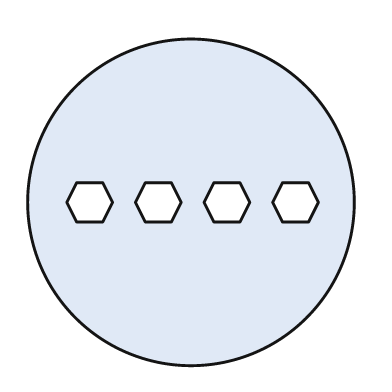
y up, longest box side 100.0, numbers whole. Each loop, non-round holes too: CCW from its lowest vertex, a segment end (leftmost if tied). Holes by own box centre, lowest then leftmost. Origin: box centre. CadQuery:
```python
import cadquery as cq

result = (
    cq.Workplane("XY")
    .moveTo(0.0, 0.0)
    .circle(50.0)
    .moveTo(-35.0, -6.0)
    .lineTo(-27.0, -6.0)
    .lineTo(-24.0, 0.0)
    .lineTo(-27.0, 6.0)
    .lineTo(-35.0, 6.0)
    .lineTo(-38.0, 0.0)
    .close()
    .moveTo(-14.0, -6.0)
    .lineTo(-6.0, -6.0)
    .lineTo(-3.0, 0.0)
    .lineTo(-6.0, 6.0)
    .lineTo(-14.0, 6.0)
    .lineTo(-17.0, 0.0)
    .close()
    .moveTo(7.0, -6.0)
    .lineTo(15.0, -6.0)
    .lineTo(18.0, 0.0)
    .lineTo(15.0, 6.0)
    .lineTo(7.0, 6.0)
    .lineTo(4.0, 0.0)
    .close()
    .moveTo(28.0, -6.0)
    .lineTo(36.0, -6.0)
    .lineTo(39.0, 0.0)
    .lineTo(36.0, 6.0)
    .lineTo(28.0, 6.0)
    .lineTo(25.0, 0.0)
    .close()
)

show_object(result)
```